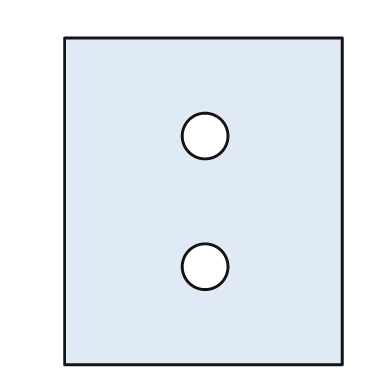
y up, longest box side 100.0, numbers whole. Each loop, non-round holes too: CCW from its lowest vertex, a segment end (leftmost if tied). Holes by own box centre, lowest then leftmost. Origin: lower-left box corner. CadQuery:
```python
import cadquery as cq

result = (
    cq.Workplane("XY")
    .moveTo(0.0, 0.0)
    .lineTo(85.0, 0.0)
    .lineTo(85.0, 100.0)
    .lineTo(0.0, 100.0)
    .close()
    .moveTo(43.0, 30.0)
    .circle(7.0)
    .moveTo(43.0, 70.0)
    .circle(7.0)
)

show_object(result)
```